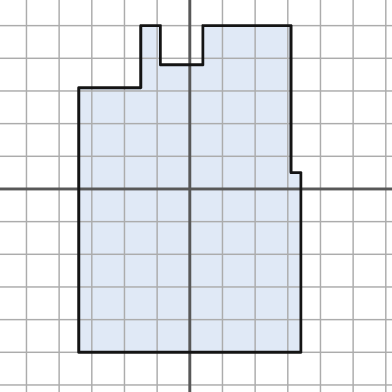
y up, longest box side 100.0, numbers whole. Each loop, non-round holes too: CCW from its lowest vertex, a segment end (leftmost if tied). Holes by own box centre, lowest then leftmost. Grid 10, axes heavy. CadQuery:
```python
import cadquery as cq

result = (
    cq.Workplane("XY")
    .moveTo(-34.0, -50.0)
    .lineTo(34.0, -50.0)
    .lineTo(34.0, 5.0)
    .lineTo(31.0, 5.0)
    .lineTo(31.0, 50.0)
    .lineTo(4.0, 50.0)
    .lineTo(4.0, 38.0)
    .lineTo(-9.0, 38.0)
    .lineTo(-9.0, 50.0)
    .lineTo(-15.0, 50.0)
    .lineTo(-15.0, 31.0)
    .lineTo(-34.0, 31.0)
    .close()
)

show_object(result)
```